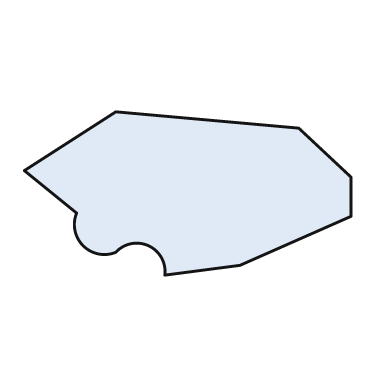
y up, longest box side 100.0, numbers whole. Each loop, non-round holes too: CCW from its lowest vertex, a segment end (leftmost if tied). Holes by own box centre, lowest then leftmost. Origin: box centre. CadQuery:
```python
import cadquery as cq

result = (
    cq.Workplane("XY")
    .moveTo(-7.0, -25.0)
    .lineTo(16.0, -22.0)
    .lineTo(50.0, -7.0)
    .lineTo(50.0, 5.0)
    .lineTo(34.0, 20.0)
    .lineTo(-22.0, 25.0)
    .lineTo(-50.0, 7.0)
    .lineTo(-34.0, -6.0)
    .threePointArc((-32.0, -16.0), (-22.0, -18.0))
    .threePointArc((-12.0, -16.0), (-7.0, -25.0))
    .close()
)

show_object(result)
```